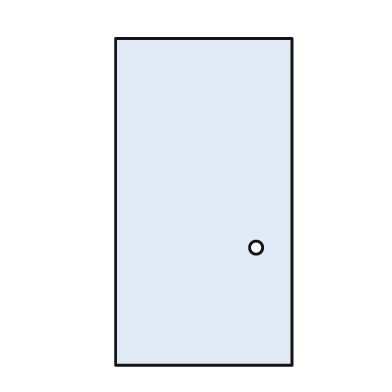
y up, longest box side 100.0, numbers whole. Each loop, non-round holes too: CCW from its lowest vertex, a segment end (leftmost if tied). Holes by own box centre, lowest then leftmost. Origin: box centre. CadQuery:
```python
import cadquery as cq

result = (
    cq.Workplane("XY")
    .moveTo(-27.0, -50.0)
    .lineTo(27.0, -50.0)
    .lineTo(27.0, 50.0)
    .lineTo(-27.0, 50.0)
    .close()
    .moveTo(16.0, -14.0)
    .circle(2.0)
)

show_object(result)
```